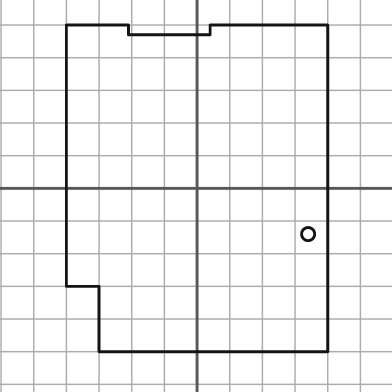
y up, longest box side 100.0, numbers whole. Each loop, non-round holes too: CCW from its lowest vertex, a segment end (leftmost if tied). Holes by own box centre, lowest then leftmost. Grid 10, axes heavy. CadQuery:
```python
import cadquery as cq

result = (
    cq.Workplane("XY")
    .moveTo(-30.0, -50.0)
    .lineTo(40.0, -50.0)
    .lineTo(40.0, 50.0)
    .lineTo(4.0, 50.0)
    .lineTo(4.0, 47.0)
    .lineTo(-21.0, 47.0)
    .lineTo(-21.0, 50.0)
    .lineTo(-40.0, 50.0)
    .lineTo(-40.0, -30.0)
    .lineTo(-30.0, -30.0)
    .close()
    .moveTo(34.0, -14.0)
    .circle(2.0)
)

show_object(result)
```